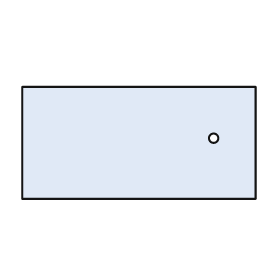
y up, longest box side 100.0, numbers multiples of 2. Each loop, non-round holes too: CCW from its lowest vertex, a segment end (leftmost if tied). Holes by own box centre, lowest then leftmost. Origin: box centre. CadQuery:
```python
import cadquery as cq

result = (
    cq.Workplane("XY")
    .moveTo(-50.0, -24.0)
    .lineTo(50.0, -24.0)
    .lineTo(50.0, 24.0)
    .lineTo(-50.0, 24.0)
    .close()
    .moveTo(32.0, 2.0)
    .circle(2.0)
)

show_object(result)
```